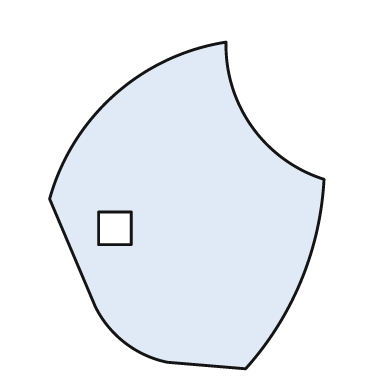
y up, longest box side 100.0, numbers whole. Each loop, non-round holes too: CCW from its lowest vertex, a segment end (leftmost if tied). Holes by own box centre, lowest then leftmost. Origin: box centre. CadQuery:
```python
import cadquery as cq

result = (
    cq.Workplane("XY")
    .moveTo(18.0, -50.0)
    .threePointArc((35.0, -23.0), (42.0, 8.0))
    .threePointArc((20.0, 24.0), (12.0, 50.0))
    .threePointArc((-22.0, 34.0), (-42.0, 2.0))
    .lineTo(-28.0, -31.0)
    .threePointArc((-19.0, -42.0), (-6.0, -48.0))
    .close()
    .moveTo(-27.0, -12.0)
    .lineTo(-17.0, -12.0)
    .lineTo(-17.0, -2.0)
    .lineTo(-27.0, -2.0)
    .close()
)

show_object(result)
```